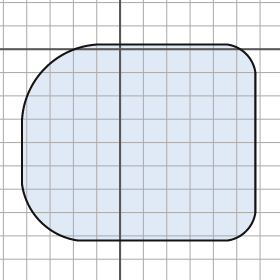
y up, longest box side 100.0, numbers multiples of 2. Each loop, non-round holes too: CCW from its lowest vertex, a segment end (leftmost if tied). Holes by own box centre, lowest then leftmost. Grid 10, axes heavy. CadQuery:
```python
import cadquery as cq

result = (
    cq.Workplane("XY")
    .moveTo(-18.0, -82.0)
    .lineTo(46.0, -82.0)
    .threePointArc((54.0, -78.0), (58.0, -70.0))
    .lineTo(58.0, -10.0)
    .threePointArc((54.0, -2.0), (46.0, 2.0))
    .lineTo(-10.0, 2.0)
    .threePointArc((-32.0, -8.0), (-42.0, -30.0))
    .lineTo(-42.0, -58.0)
    .threePointArc((-34.0, -74.0), (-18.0, -82.0))
    .close()
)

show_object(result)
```